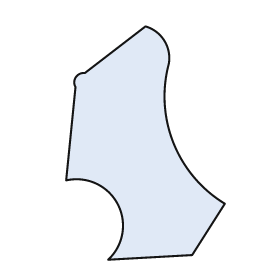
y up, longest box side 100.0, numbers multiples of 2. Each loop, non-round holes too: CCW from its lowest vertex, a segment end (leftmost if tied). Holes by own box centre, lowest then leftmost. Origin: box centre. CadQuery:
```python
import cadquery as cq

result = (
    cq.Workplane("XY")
    .moveTo(-16.0, -50.0)
    .lineTo(20.0, -48.0)
    .lineTo(34.0, -26.0)
    .threePointArc((12.0, 0.0), (10.0, 34.0))
    .threePointArc((8.0, 44.0), (0.0, 50.0))
    .lineTo(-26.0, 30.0)
    .threePointArc((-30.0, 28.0), (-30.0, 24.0))
    .lineTo(-34.0, -16.0)
    .threePointArc((-12.0, -26.0), (-16.0, -50.0))
    .close()
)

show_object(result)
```